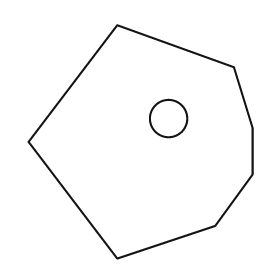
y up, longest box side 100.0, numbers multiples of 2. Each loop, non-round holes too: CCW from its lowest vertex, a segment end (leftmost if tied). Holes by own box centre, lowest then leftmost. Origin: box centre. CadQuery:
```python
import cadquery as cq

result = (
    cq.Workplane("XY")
    .moveTo(-10.0, -50.0)
    .lineTo(32.0, -36.0)
    .lineTo(48.0, -14.0)
    .lineTo(48.0, 6.0)
    .lineTo(40.0, 32.0)
    .lineTo(-10.0, 50.0)
    .lineTo(-48.0, 0.0)
    .close()
    .moveTo(12.0, 10.0)
    .circle(8.0)
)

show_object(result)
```